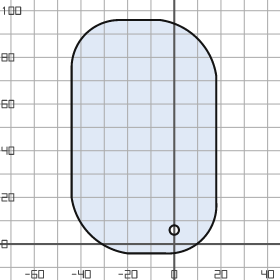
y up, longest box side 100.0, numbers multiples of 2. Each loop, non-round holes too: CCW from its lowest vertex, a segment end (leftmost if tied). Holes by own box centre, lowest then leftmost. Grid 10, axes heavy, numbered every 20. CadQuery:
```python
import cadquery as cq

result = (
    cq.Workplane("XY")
    .moveTo(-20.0, -4.0)
    .lineTo(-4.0, -4.0)
    .threePointArc((12.0, 2.0), (18.0, 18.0))
    .lineTo(18.0, 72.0)
    .threePointArc((10.0, 88.0), (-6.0, 96.0))
    .lineTo(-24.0, 96.0)
    .threePointArc((-38.0, 90.0), (-44.0, 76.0))
    .lineTo(-44.0, 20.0)
    .threePointArc((-36.0, 4.0), (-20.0, -4.0))
    .close()
    .moveTo(0.0, 6.0)
    .circle(2.0)
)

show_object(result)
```